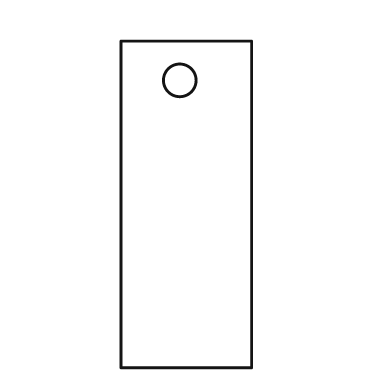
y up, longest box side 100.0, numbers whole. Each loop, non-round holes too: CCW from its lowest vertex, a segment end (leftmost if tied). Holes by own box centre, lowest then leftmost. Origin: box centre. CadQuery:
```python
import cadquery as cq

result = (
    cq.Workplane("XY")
    .moveTo(-20.0, -50.0)
    .lineTo(20.0, -50.0)
    .lineTo(20.0, 50.0)
    .lineTo(-20.0, 50.0)
    .close()
    .moveTo(-2.0, 38.0)
    .circle(5.0)
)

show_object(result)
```